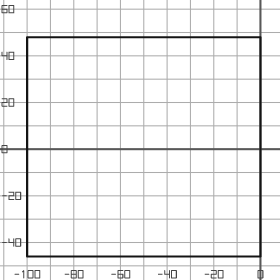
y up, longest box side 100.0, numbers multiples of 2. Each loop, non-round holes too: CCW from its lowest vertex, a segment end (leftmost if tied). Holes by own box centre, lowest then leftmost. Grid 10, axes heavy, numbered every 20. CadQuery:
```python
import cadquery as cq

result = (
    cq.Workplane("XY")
    .moveTo(-100.0, -46.0)
    .lineTo(0.0, -46.0)
    .lineTo(0.0, 48.0)
    .lineTo(-100.0, 48.0)
    .close()
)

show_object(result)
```